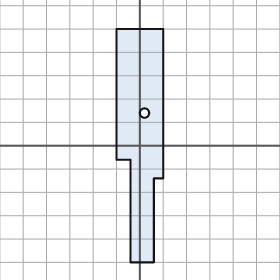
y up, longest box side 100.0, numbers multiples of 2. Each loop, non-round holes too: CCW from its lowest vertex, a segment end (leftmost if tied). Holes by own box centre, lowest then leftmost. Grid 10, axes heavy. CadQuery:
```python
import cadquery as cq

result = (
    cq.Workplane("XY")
    .moveTo(-4.0, -50.0)
    .lineTo(6.0, -50.0)
    .lineTo(6.0, -14.0)
    .lineTo(10.0, -14.0)
    .lineTo(10.0, 50.0)
    .lineTo(-10.0, 50.0)
    .lineTo(-10.0, -6.0)
    .lineTo(-4.0, -6.0)
    .close()
    .moveTo(2.0, 14.0)
    .circle(2.0)
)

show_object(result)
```